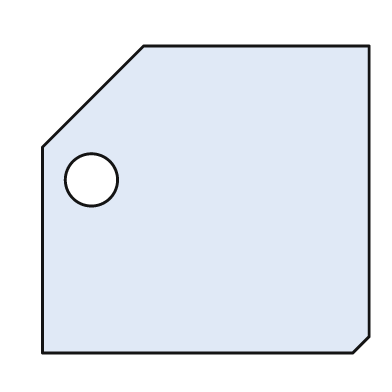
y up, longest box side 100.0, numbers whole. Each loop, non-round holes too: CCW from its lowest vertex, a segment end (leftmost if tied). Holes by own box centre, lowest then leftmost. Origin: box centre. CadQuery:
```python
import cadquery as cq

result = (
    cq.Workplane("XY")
    .moveTo(-50.0, -47.0)
    .lineTo(45.0, -47.0)
    .lineTo(50.0, -42.0)
    .lineTo(50.0, 47.0)
    .lineTo(-19.0, 47.0)
    .lineTo(-50.0, 16.0)
    .close()
    .moveTo(-35.0, 6.0)
    .circle(8.0)
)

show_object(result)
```